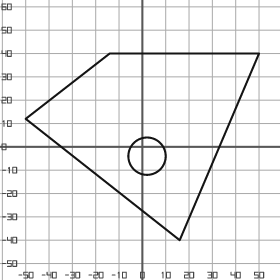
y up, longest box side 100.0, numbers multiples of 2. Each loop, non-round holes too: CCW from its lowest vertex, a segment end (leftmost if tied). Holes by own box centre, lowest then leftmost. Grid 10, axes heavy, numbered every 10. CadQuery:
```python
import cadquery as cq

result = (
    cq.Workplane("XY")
    .moveTo(16.0, -40.0)
    .lineTo(50.0, 40.0)
    .lineTo(-14.0, 40.0)
    .lineTo(-50.0, 12.0)
    .close()
    .moveTo(2.0, -4.0)
    .circle(8.0)
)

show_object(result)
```